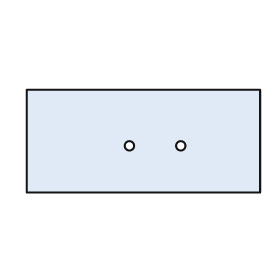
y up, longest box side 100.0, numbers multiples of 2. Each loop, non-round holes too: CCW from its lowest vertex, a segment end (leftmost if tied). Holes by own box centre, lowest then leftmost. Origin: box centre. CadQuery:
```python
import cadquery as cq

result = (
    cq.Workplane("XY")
    .moveTo(-50.0, -22.0)
    .lineTo(50.0, -22.0)
    .lineTo(50.0, 22.0)
    .lineTo(-50.0, 22.0)
    .close()
    .moveTo(-6.0, -2.0)
    .circle(2.0)
    .moveTo(16.0, -2.0)
    .circle(2.0)
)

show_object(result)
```